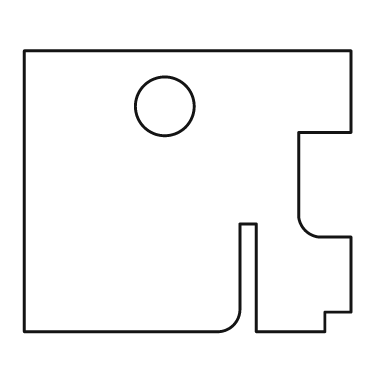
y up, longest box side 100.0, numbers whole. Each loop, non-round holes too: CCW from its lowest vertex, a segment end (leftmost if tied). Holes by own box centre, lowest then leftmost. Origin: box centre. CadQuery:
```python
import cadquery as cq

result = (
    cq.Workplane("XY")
    .moveTo(-50.0, -43.0)
    .lineTo(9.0, -43.0)
    .threePointArc((14.0, -41.0), (16.0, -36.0))
    .lineTo(16.0, -10.0)
    .lineTo(21.0, -10.0)
    .lineTo(21.0, -43.0)
    .lineTo(42.0, -43.0)
    .lineTo(42.0, -37.0)
    .lineTo(50.0, -37.0)
    .lineTo(50.0, -14.0)
    .lineTo(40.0, -14.0)
    .threePointArc((36.0, -12.0), (34.0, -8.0))
    .lineTo(34.0, 18.0)
    .lineTo(50.0, 18.0)
    .lineTo(50.0, 43.0)
    .lineTo(-50.0, 43.0)
    .close()
    .moveTo(-7.0, 26.0)
    .circle(9.0)
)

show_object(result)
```